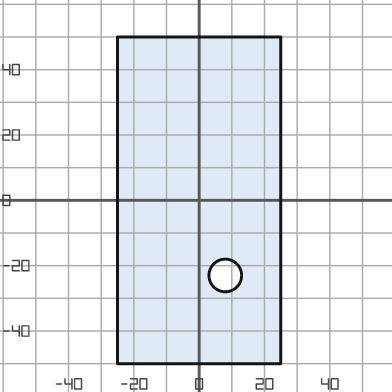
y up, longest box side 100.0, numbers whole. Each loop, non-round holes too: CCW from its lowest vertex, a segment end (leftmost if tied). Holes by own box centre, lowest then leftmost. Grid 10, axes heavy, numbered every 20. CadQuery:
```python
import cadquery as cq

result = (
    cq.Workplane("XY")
    .moveTo(-25.0, -50.0)
    .lineTo(25.0, -50.0)
    .lineTo(25.0, 50.0)
    .lineTo(-25.0, 50.0)
    .close()
    .moveTo(8.0, -23.0)
    .circle(5.0)
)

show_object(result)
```